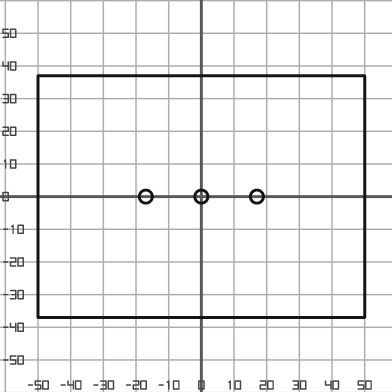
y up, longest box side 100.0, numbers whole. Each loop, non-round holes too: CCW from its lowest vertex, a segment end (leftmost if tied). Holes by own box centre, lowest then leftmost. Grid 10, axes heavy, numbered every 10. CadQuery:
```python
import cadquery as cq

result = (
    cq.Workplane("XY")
    .moveTo(-50.0, -37.0)
    .lineTo(50.0, -37.0)
    .lineTo(50.0, 37.0)
    .lineTo(-50.0, 37.0)
    .close()
    .moveTo(-17.0, 0.0)
    .circle(2.0)
    .moveTo(0.0, 0.0)
    .circle(2.0)
    .moveTo(17.0, 0.0)
    .circle(2.0)
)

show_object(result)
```